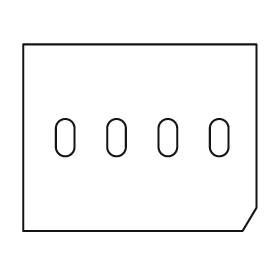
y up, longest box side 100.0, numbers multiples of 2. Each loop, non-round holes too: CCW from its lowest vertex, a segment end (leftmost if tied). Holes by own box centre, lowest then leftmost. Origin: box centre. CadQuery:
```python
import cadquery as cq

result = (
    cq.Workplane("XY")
    .moveTo(-50.0, -40.0)
    .lineTo(44.0, -40.0)
    .lineTo(50.0, -30.0)
    .lineTo(50.0, 40.0)
    .lineTo(-50.0, 40.0)
    .close()
    .moveTo(-36.0, -4.0)
    .threePointArc((-32.0, -8.0), (-28.0, -4.0))
    .lineTo(-28.0, 4.0)
    .threePointArc((-32.0, 8.0), (-36.0, 4.0))
    .close()
    .moveTo(-14.0, -4.0)
    .threePointArc((-10.0, -8.0), (-6.0, -4.0))
    .lineTo(-6.0, 4.0)
    .threePointArc((-10.0, 8.0), (-14.0, 4.0))
    .close()
    .moveTo(8.0, -4.0)
    .threePointArc((12.0, -8.0), (16.0, -4.0))
    .lineTo(16.0, 4.0)
    .threePointArc((12.0, 8.0), (8.0, 4.0))
    .close()
    .moveTo(30.0, -4.0)
    .threePointArc((34.0, -8.0), (38.0, -4.0))
    .lineTo(38.0, 4.0)
    .threePointArc((34.0, 8.0), (30.0, 4.0))
    .close()
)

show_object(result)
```